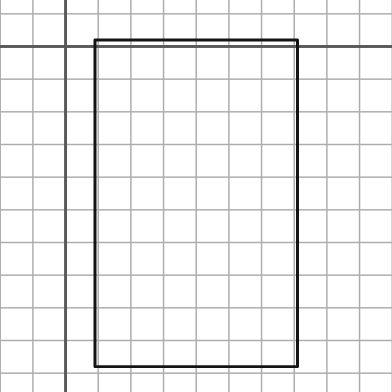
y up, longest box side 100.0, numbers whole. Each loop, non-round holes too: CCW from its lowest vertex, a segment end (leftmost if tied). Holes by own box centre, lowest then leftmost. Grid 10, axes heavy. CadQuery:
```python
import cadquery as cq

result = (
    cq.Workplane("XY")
    .moveTo(9.0, -98.0)
    .lineTo(71.0, -98.0)
    .lineTo(71.0, 2.0)
    .lineTo(9.0, 2.0)
    .close()
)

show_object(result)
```